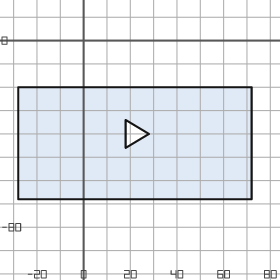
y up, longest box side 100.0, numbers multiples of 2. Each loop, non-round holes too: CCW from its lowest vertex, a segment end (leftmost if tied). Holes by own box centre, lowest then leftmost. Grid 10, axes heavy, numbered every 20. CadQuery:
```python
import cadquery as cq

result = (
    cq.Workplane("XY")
    .moveTo(-28.0, -68.0)
    .lineTo(72.0, -68.0)
    .lineTo(72.0, -20.0)
    .lineTo(-28.0, -20.0)
    .close()
    .moveTo(18.0, -46.0)
    .lineTo(28.0, -40.0)
    .lineTo(18.0, -34.0)
    .close()
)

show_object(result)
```